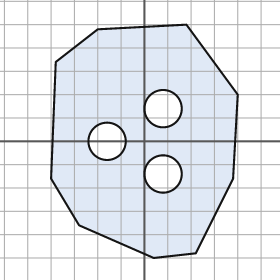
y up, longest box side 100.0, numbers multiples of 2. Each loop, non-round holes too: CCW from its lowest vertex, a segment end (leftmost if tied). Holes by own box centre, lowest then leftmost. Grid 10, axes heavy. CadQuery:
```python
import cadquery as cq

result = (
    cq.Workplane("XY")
    .moveTo(4.0, -50.0)
    .lineTo(22.0, -48.0)
    .lineTo(38.0, -16.0)
    .lineTo(40.0, 20.0)
    .lineTo(18.0, 50.0)
    .lineTo(-20.0, 48.0)
    .lineTo(-38.0, 34.0)
    .lineTo(-40.0, -16.0)
    .lineTo(-28.0, -36.0)
    .close()
    .moveTo(8.0, -14.0)
    .circle(8.0)
    .moveTo(-16.0, 0.0)
    .circle(8.0)
    .moveTo(8.0, 14.0)
    .circle(8.0)
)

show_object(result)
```